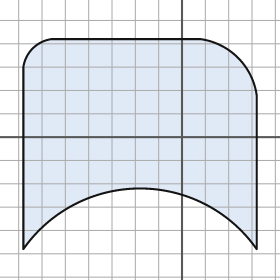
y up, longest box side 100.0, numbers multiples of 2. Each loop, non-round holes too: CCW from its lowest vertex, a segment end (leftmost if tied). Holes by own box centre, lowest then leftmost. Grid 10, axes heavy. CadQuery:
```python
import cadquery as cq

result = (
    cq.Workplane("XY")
    .moveTo(-68.0, -48.0)
    .threePointArc((-18.0, -22.0), (32.0, -48.0))
    .lineTo(32.0, 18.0)
    .threePointArc((24.0, 34.0), (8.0, 42.0))
    .lineTo(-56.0, 42.0)
    .threePointArc((-64.0, 38.0), (-68.0, 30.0))
    .close()
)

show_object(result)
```